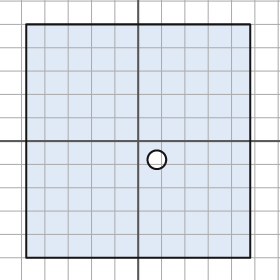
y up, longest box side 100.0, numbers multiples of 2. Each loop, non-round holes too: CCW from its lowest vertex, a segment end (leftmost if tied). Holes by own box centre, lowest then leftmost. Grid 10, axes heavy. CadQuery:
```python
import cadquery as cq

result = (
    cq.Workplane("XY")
    .moveTo(-48.0, -50.0)
    .lineTo(48.0, -50.0)
    .lineTo(48.0, 50.0)
    .lineTo(-48.0, 50.0)
    .close()
    .moveTo(8.0, -8.0)
    .circle(4.0)
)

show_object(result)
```